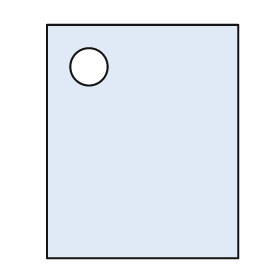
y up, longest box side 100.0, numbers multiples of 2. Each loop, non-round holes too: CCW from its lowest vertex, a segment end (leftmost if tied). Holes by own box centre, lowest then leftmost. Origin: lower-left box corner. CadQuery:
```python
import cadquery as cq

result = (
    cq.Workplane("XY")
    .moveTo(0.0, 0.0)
    .lineTo(82.0, 0.0)
    .lineTo(82.0, 100.0)
    .lineTo(0.0, 100.0)
    .close()
    .moveTo(18.0, 82.0)
    .circle(8.0)
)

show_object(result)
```